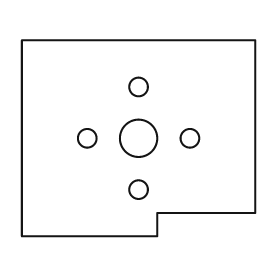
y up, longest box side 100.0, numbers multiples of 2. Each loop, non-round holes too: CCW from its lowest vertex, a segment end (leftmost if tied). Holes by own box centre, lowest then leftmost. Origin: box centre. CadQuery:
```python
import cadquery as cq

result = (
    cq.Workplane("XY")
    .moveTo(-50.0, -42.0)
    .lineTo(8.0, -42.0)
    .lineTo(8.0, -32.0)
    .lineTo(50.0, -32.0)
    .lineTo(50.0, 42.0)
    .lineTo(-50.0, 42.0)
    .close()
    .moveTo(0.0, -22.0)
    .circle(4.0)
    .moveTo(-22.0, 0.0)
    .circle(4.0)
    .moveTo(0.0, 0.0)
    .circle(8.0)
    .moveTo(22.0, 0.0)
    .circle(4.0)
    .moveTo(0.0, 22.0)
    .circle(4.0)
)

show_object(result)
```